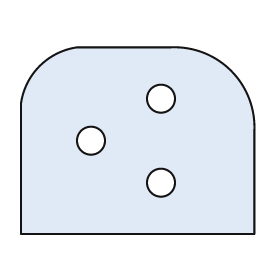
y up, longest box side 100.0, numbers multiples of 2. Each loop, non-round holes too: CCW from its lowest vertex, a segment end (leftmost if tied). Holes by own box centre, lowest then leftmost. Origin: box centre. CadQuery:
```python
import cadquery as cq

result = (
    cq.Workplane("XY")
    .moveTo(-50.0, -40.0)
    .lineTo(50.0, -40.0)
    .lineTo(50.0, 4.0)
    .threePointArc((40.0, 30.0), (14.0, 40.0))
    .lineTo(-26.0, 40.0)
    .threePointArc((-42.0, 32.0), (-50.0, 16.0))
    .close()
    .moveTo(10.0, -18.0)
    .circle(6.0)
    .moveTo(-20.0, 0.0)
    .circle(6.0)
    .moveTo(10.0, 18.0)
    .circle(6.0)
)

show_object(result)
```